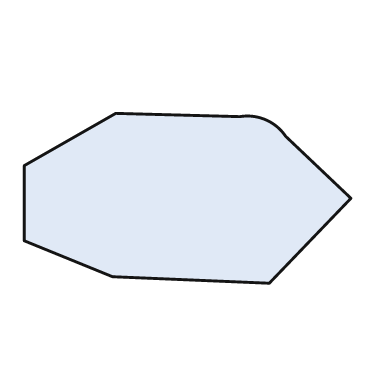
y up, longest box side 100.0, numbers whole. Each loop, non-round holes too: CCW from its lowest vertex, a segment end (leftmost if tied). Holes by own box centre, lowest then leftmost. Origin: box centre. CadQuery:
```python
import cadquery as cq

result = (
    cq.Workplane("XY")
    .moveTo(25.0, -26.0)
    .lineTo(50.0, 0.0)
    .lineTo(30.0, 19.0)
    .threePointArc((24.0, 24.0), (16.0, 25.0))
    .lineTo(-22.0, 26.0)
    .lineTo(-50.0, 10.0)
    .lineTo(-50.0, -13.0)
    .lineTo(-23.0, -24.0)
    .close()
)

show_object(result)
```